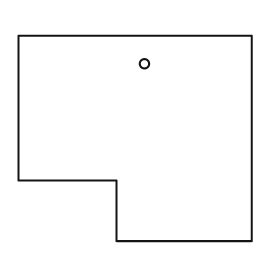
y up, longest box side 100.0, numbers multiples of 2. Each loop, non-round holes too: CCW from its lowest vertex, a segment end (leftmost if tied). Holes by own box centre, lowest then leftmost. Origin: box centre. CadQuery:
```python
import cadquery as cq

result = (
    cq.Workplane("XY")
    .moveTo(-8.0, -44.0)
    .lineTo(50.0, -44.0)
    .lineTo(50.0, 44.0)
    .lineTo(-50.0, 44.0)
    .lineTo(-50.0, -18.0)
    .lineTo(-8.0, -18.0)
    .close()
    .moveTo(4.0, 32.0)
    .circle(2.0)
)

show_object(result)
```